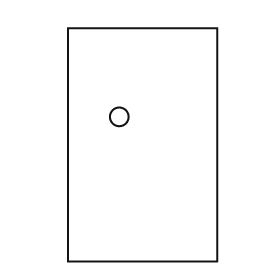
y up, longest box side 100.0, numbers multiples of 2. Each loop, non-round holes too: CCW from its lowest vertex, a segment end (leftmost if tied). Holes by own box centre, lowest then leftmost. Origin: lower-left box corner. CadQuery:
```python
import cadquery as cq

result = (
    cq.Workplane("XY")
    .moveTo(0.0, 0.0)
    .lineTo(64.0, 0.0)
    .lineTo(64.0, 100.0)
    .lineTo(0.0, 100.0)
    .close()
    .moveTo(22.0, 62.0)
    .circle(4.0)
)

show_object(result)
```